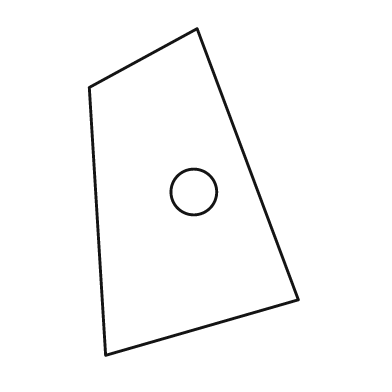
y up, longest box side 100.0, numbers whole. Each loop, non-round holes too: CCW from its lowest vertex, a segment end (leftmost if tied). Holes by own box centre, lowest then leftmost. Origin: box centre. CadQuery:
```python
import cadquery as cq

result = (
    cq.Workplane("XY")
    .moveTo(-27.0, -50.0)
    .lineTo(32.0, -33.0)
    .lineTo(1.0, 50.0)
    .lineTo(-32.0, 32.0)
    .close()
    .moveTo(0.0, 0.0)
    .circle(7.0)
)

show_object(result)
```